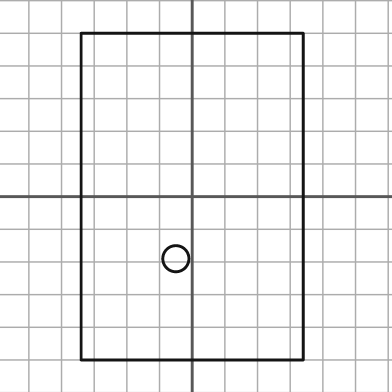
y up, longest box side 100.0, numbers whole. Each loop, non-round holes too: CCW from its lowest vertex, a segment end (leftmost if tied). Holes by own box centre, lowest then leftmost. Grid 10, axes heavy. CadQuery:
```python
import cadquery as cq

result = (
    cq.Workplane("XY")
    .moveTo(-34.0, -50.0)
    .lineTo(34.0, -50.0)
    .lineTo(34.0, 50.0)
    .lineTo(-34.0, 50.0)
    .close()
    .moveTo(-5.0, -19.0)
    .circle(4.0)
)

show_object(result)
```